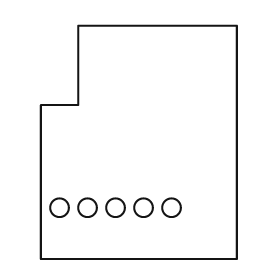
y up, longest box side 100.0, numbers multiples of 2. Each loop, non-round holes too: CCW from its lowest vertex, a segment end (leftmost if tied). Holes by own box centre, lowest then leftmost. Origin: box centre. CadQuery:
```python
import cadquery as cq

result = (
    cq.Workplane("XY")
    .moveTo(-42.0, -50.0)
    .lineTo(42.0, -50.0)
    .lineTo(42.0, 50.0)
    .lineTo(-26.0, 50.0)
    .lineTo(-26.0, 16.0)
    .lineTo(-42.0, 16.0)
    .close()
    .moveTo(-34.0, -28.0)
    .circle(4.0)
    .moveTo(-22.0, -28.0)
    .circle(4.0)
    .moveTo(-10.0, -28.0)
    .circle(4.0)
    .moveTo(2.0, -28.0)
    .circle(4.0)
    .moveTo(14.0, -28.0)
    .circle(4.0)
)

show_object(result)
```